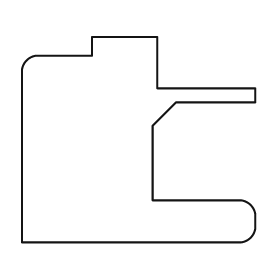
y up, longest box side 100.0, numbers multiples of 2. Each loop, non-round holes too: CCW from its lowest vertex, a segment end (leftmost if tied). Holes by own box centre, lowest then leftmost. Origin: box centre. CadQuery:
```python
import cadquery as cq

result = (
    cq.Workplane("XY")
    .moveTo(-50.0, -44.0)
    .lineTo(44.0, -44.0)
    .threePointArc((48.0, -42.0), (50.0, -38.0))
    .lineTo(50.0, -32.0)
    .threePointArc((48.0, -28.0), (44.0, -26.0))
    .lineTo(6.0, -26.0)
    .lineTo(6.0, 6.0)
    .lineTo(16.0, 16.0)
    .lineTo(50.0, 16.0)
    .lineTo(50.0, 22.0)
    .lineTo(8.0, 22.0)
    .lineTo(8.0, 44.0)
    .lineTo(-20.0, 44.0)
    .lineTo(-20.0, 36.0)
    .lineTo(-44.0, 36.0)
    .threePointArc((-48.0, 34.0), (-50.0, 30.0))
    .close()
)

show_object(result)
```